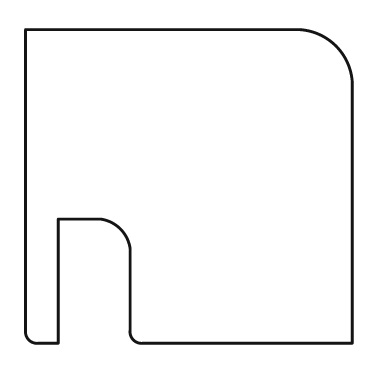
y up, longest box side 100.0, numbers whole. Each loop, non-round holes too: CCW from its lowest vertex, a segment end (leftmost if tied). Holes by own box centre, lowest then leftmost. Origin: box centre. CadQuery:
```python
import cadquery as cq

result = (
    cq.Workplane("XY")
    .moveTo(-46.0, -48.0)
    .lineTo(-40.0, -48.0)
    .lineTo(-40.0, -10.0)
    .lineTo(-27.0, -10.0)
    .threePointArc((-21.0, -13.0), (-18.0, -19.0))
    .lineTo(-18.0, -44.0)
    .threePointArc((-17.0, -47.0), (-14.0, -48.0))
    .lineTo(50.0, -48.0)
    .lineTo(50.0, 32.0)
    .threePointArc((45.0, 43.0), (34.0, 48.0))
    .lineTo(-50.0, 48.0)
    .lineTo(-50.0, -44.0)
    .threePointArc((-49.0, -47.0), (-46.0, -48.0))
    .close()
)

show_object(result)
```